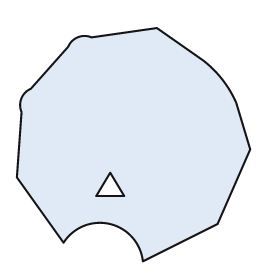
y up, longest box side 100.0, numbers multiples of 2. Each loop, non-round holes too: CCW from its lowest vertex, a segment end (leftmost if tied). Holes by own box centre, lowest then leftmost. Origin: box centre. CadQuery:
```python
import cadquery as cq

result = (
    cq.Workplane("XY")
    .moveTo(4.0, -50.0)
    .lineTo(36.0, -34.0)
    .lineTo(50.0, -2.0)
    .lineTo(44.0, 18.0)
    .threePointArc((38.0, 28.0), (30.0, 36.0))
    .lineTo(10.0, 50.0)
    .lineTo(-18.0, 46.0)
    .threePointArc((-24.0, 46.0), (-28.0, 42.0))
    .lineTo(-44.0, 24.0)
    .threePointArc((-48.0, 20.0), (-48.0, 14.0))
    .lineTo(-50.0, -14.0)
    .lineTo(-30.0, -42.0)
    .threePointArc((-10.0, -34.0), (4.0, -50.0))
    .close()
    .moveTo(-16.0, -22.0)
    .lineTo(-4.0, -22.0)
    .lineTo(-10.0, -12.0)
    .close()
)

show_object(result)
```